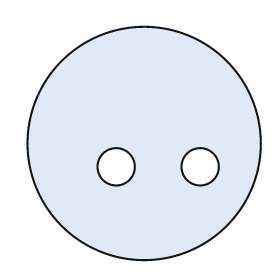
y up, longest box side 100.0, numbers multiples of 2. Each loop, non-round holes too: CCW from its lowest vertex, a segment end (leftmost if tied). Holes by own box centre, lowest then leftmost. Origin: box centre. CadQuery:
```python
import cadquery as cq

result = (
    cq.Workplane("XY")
    .moveTo(0.0, 0.0)
    .circle(50.0)
    .moveTo(-12.0, -10.0)
    .circle(8.0)
    .moveTo(24.0, -10.0)
    .circle(8.0)
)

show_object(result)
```